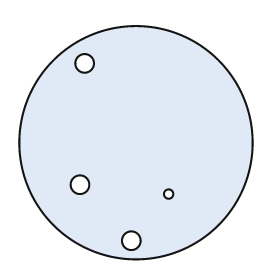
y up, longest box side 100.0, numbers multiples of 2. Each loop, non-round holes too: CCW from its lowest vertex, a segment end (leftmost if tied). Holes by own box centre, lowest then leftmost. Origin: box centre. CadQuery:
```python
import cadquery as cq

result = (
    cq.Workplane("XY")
    .moveTo(0.0, 0.0)
    .circle(50.0)
    .moveTo(-2.0, -42.0)
    .circle(4.0)
    .moveTo(14.0, -22.0)
    .circle(2.0)
    .moveTo(-24.0, -18.0)
    .circle(4.0)
    .moveTo(-22.0, 34.0)
    .circle(4.0)
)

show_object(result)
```